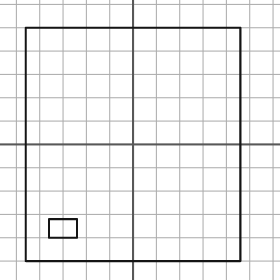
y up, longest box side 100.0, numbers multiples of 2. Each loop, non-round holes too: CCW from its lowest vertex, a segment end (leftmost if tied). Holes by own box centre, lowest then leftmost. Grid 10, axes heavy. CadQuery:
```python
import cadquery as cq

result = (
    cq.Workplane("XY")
    .moveTo(-46.0, -50.0)
    .lineTo(46.0, -50.0)
    .lineTo(46.0, 50.0)
    .lineTo(-46.0, 50.0)
    .close()
    .moveTo(-36.0, -40.0)
    .lineTo(-24.0, -40.0)
    .lineTo(-24.0, -32.0)
    .lineTo(-36.0, -32.0)
    .close()
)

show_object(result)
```